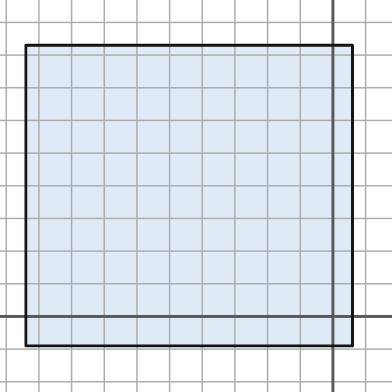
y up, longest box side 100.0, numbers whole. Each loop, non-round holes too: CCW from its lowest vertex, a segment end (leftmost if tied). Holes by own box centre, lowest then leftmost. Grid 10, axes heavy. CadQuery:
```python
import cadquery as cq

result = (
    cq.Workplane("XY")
    .moveTo(-94.0, -9.0)
    .lineTo(6.0, -9.0)
    .lineTo(6.0, 83.0)
    .lineTo(-94.0, 83.0)
    .close()
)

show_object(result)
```